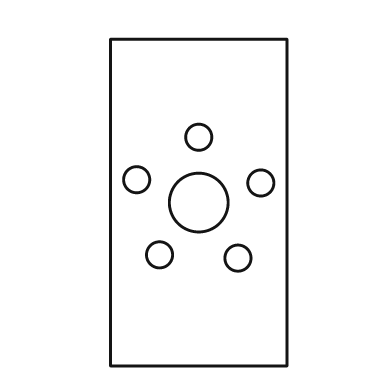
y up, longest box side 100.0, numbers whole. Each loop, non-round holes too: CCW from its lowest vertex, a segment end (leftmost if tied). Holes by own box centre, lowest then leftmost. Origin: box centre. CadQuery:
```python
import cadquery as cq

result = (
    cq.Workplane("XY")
    .moveTo(-27.0, -50.0)
    .lineTo(27.0, -50.0)
    .lineTo(27.0, 50.0)
    .lineTo(-27.0, 50.0)
    .close()
    .moveTo(12.0, -17.0)
    .circle(4.0)
    .moveTo(-12.0, -16.0)
    .circle(4.0)
    .moveTo(0.0, 0.0)
    .circle(9.0)
    .moveTo(19.0, 6.0)
    .circle(4.0)
    .moveTo(-19.0, 7.0)
    .circle(4.0)
    .moveTo(0.0, 20.0)
    .circle(4.0)
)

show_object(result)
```